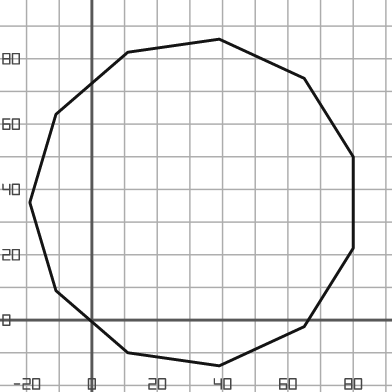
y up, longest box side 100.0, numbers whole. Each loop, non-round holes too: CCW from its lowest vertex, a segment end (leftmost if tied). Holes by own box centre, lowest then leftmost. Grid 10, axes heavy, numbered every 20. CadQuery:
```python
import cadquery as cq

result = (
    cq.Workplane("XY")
    .moveTo(39.0, -14.0)
    .lineTo(65.0, -2.0)
    .lineTo(80.0, 22.0)
    .lineTo(80.0, 50.0)
    .lineTo(65.0, 74.0)
    .lineTo(39.0, 86.0)
    .lineTo(11.0, 82.0)
    .lineTo(-11.0, 63.0)
    .lineTo(-19.0, 36.0)
    .lineTo(-11.0, 9.0)
    .lineTo(11.0, -10.0)
    .close()
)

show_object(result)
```